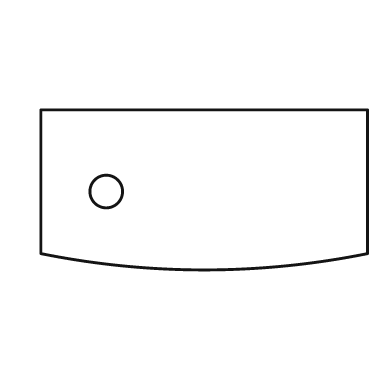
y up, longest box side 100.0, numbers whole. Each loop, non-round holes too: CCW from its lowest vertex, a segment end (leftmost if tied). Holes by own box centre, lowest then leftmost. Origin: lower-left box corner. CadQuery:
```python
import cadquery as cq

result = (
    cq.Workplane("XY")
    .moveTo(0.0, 5.0)
    .threePointArc((50.0, 0.0), (100.0, 5.0))
    .lineTo(100.0, 49.0)
    .lineTo(0.0, 49.0)
    .close()
    .moveTo(20.0, 24.0)
    .circle(5.0)
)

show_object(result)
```